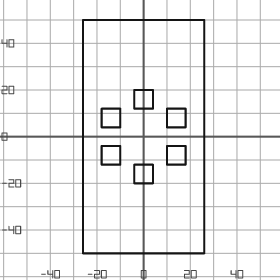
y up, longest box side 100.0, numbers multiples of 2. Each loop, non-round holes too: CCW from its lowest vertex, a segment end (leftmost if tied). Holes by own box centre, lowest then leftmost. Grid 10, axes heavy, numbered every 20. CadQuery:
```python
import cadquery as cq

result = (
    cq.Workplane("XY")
    .moveTo(-26.0, -50.0)
    .lineTo(26.0, -50.0)
    .lineTo(26.0, 50.0)
    .lineTo(-26.0, 50.0)
    .close()
    .moveTo(-4.0, -20.0)
    .lineTo(4.0, -20.0)
    .lineTo(4.0, -12.0)
    .lineTo(-4.0, -12.0)
    .close()
    .moveTo(-18.0, -12.0)
    .lineTo(-10.0, -12.0)
    .lineTo(-10.0, -4.0)
    .lineTo(-18.0, -4.0)
    .close()
    .moveTo(10.0, -12.0)
    .lineTo(18.0, -12.0)
    .lineTo(18.0, -4.0)
    .lineTo(10.0, -4.0)
    .close()
    .moveTo(-18.0, 4.0)
    .lineTo(-10.0, 4.0)
    .lineTo(-10.0, 12.0)
    .lineTo(-18.0, 12.0)
    .close()
    .moveTo(10.0, 4.0)
    .lineTo(18.0, 4.0)
    .lineTo(18.0, 12.0)
    .lineTo(10.0, 12.0)
    .close()
    .moveTo(-4.0, 12.0)
    .lineTo(4.0, 12.0)
    .lineTo(4.0, 20.0)
    .lineTo(-4.0, 20.0)
    .close()
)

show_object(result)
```